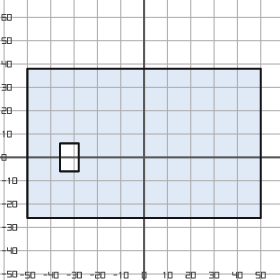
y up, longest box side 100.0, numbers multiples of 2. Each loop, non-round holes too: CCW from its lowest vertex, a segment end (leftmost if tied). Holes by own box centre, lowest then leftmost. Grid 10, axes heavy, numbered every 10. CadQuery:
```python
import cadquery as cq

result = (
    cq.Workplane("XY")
    .moveTo(-50.0, -26.0)
    .lineTo(50.0, -26.0)
    .lineTo(50.0, 38.0)
    .lineTo(-50.0, 38.0)
    .close()
    .moveTo(-36.0, -6.0)
    .lineTo(-28.0, -6.0)
    .lineTo(-28.0, 6.0)
    .lineTo(-36.0, 6.0)
    .close()
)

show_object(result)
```